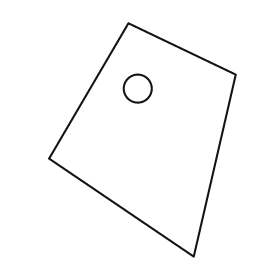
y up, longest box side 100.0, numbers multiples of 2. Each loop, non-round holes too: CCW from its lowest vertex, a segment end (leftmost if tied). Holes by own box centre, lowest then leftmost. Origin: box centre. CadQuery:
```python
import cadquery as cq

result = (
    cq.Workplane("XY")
    .moveTo(22.0, -50.0)
    .lineTo(40.0, 28.0)
    .lineTo(-6.0, 50.0)
    .lineTo(-40.0, -8.0)
    .close()
    .moveTo(-2.0, 22.0)
    .circle(6.0)
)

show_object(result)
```